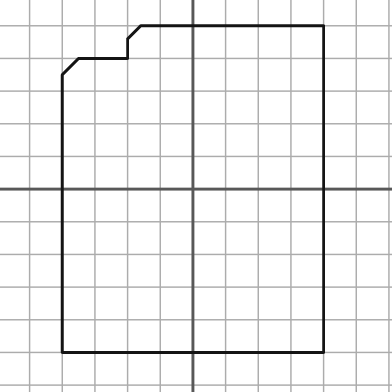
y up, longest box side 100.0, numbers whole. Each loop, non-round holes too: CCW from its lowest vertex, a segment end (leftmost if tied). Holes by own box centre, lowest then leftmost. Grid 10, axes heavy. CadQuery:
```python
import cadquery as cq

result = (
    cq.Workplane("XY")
    .moveTo(-40.0, -50.0)
    .lineTo(40.0, -50.0)
    .lineTo(40.0, 50.0)
    .lineTo(-16.0, 50.0)
    .lineTo(-20.0, 46.0)
    .lineTo(-20.0, 40.0)
    .lineTo(-35.0, 40.0)
    .lineTo(-40.0, 35.0)
    .close()
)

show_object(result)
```